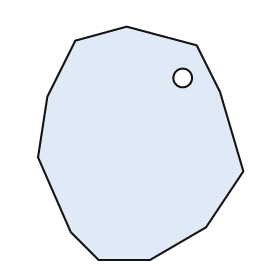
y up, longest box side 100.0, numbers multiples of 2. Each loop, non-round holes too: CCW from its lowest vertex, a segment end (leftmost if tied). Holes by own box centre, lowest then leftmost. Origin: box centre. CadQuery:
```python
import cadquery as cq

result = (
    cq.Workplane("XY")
    .moveTo(-18.0, -50.0)
    .lineTo(4.0, -50.0)
    .lineTo(28.0, -36.0)
    .lineTo(44.0, -12.0)
    .lineTo(34.0, 22.0)
    .lineTo(24.0, 42.0)
    .lineTo(-6.0, 50.0)
    .lineTo(-28.0, 44.0)
    .lineTo(-40.0, 20.0)
    .lineTo(-44.0, -6.0)
    .lineTo(-30.0, -38.0)
    .close()
    .moveTo(18.0, 28.0)
    .circle(4.0)
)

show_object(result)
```